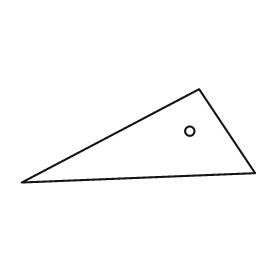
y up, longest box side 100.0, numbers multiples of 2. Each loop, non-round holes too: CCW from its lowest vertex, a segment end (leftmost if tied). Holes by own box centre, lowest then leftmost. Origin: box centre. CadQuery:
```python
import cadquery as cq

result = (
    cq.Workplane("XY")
    .moveTo(-50.0, -20.0)
    .lineTo(50.0, -16.0)
    .lineTo(26.0, 20.0)
    .close()
    .moveTo(22.0, 2.0)
    .circle(2.0)
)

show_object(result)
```